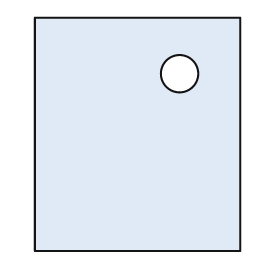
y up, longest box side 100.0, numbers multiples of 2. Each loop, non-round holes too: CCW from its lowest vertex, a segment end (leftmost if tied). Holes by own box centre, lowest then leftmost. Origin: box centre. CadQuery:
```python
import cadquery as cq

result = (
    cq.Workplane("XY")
    .moveTo(-44.0, -50.0)
    .lineTo(44.0, -50.0)
    .lineTo(44.0, 50.0)
    .lineTo(-44.0, 50.0)
    .close()
    .moveTo(18.0, 26.0)
    .circle(8.0)
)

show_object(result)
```